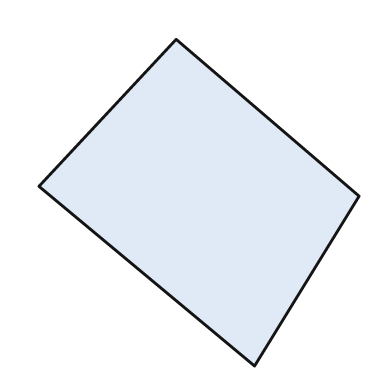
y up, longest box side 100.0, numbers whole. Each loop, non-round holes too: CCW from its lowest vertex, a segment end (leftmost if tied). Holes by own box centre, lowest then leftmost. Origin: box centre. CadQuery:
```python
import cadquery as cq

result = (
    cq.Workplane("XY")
    .moveTo(17.0, -50.0)
    .lineTo(49.0, 2.0)
    .lineTo(-7.0, 50.0)
    .lineTo(-49.0, 5.0)
    .close()
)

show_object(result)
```